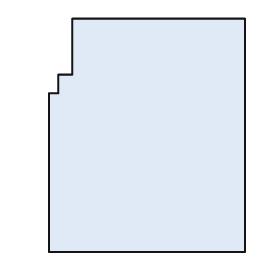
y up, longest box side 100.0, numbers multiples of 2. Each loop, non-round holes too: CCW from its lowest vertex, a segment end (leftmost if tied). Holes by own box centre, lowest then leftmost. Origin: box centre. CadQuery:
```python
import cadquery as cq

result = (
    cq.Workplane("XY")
    .moveTo(-42.0, -50.0)
    .lineTo(42.0, -50.0)
    .lineTo(42.0, 50.0)
    .lineTo(-32.0, 50.0)
    .lineTo(-32.0, 26.0)
    .lineTo(-38.0, 26.0)
    .lineTo(-38.0, 18.0)
    .lineTo(-42.0, 18.0)
    .close()
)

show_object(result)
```